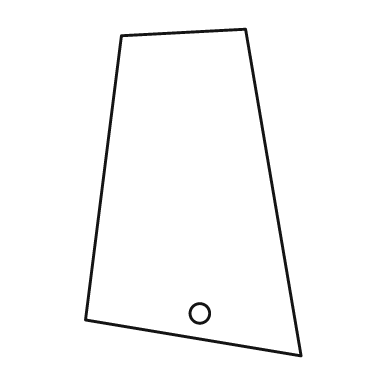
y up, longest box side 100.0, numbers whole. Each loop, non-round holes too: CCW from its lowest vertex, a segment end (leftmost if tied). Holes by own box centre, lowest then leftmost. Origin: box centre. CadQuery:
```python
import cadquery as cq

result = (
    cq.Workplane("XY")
    .moveTo(33.0, -50.0)
    .lineTo(16.0, 50.0)
    .lineTo(-22.0, 48.0)
    .lineTo(-33.0, -39.0)
    .close()
    .moveTo(2.0, -37.0)
    .circle(3.0)
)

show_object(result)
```